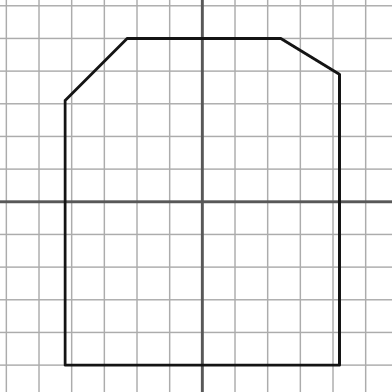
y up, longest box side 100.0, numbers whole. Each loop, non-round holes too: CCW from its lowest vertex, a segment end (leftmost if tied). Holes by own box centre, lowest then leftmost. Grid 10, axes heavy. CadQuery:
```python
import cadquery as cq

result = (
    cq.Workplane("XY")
    .moveTo(-42.0, -50.0)
    .lineTo(42.0, -50.0)
    .lineTo(42.0, 39.0)
    .lineTo(24.0, 50.0)
    .lineTo(-23.0, 50.0)
    .lineTo(-42.0, 31.0)
    .close()
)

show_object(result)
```